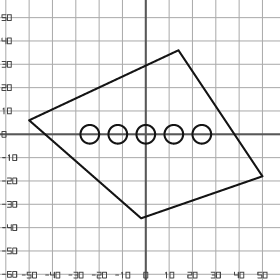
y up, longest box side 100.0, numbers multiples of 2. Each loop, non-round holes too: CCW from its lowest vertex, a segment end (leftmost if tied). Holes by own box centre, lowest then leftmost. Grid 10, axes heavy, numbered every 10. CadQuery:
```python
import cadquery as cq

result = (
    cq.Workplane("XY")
    .moveTo(-2.0, -36.0)
    .lineTo(50.0, -18.0)
    .lineTo(14.0, 36.0)
    .lineTo(-50.0, 6.0)
    .close()
    .moveTo(-24.0, 0.0)
    .circle(4.0)
    .moveTo(-12.0, 0.0)
    .circle(4.0)
    .moveTo(0.0, 0.0)
    .circle(4.0)
    .moveTo(12.0, 0.0)
    .circle(4.0)
    .moveTo(24.0, 0.0)
    .circle(4.0)
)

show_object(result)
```